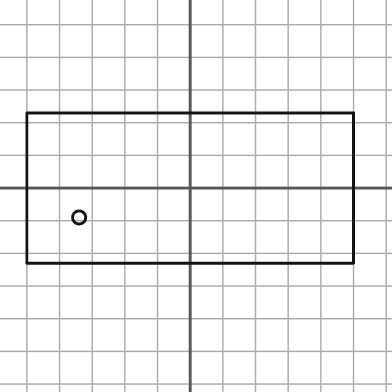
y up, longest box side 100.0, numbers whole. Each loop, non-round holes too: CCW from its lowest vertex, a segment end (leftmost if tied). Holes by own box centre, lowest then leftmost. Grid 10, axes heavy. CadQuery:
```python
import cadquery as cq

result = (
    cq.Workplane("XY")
    .moveTo(-50.0, -23.0)
    .lineTo(50.0, -23.0)
    .lineTo(50.0, 23.0)
    .lineTo(-50.0, 23.0)
    .close()
    .moveTo(-34.0, -9.0)
    .circle(2.0)
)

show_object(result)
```